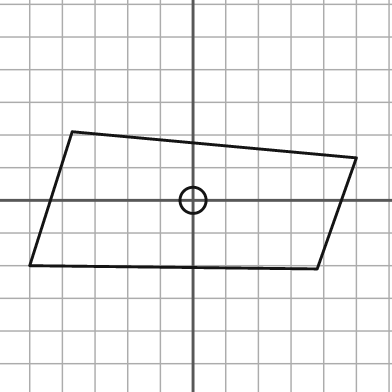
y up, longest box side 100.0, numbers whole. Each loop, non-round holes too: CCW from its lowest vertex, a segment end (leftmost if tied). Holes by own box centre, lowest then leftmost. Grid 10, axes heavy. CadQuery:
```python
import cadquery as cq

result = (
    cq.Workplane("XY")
    .moveTo(38.0, -21.0)
    .lineTo(50.0, 13.0)
    .lineTo(-37.0, 21.0)
    .lineTo(-50.0, -20.0)
    .close()
    .moveTo(0.0, 0.0)
    .circle(4.0)
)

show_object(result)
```